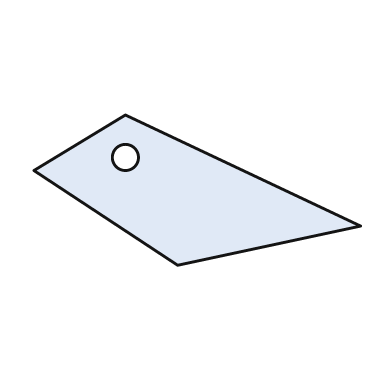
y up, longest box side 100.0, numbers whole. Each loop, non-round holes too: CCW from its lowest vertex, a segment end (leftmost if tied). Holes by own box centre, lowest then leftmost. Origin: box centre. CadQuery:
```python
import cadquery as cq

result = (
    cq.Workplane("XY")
    .moveTo(-6.0, -23.0)
    .lineTo(50.0, -11.0)
    .lineTo(-22.0, 23.0)
    .lineTo(-50.0, 6.0)
    .close()
    .moveTo(-22.0, 10.0)
    .circle(4.0)
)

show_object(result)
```